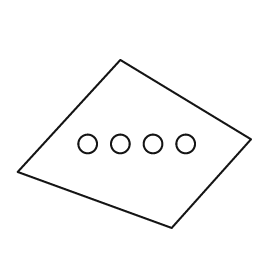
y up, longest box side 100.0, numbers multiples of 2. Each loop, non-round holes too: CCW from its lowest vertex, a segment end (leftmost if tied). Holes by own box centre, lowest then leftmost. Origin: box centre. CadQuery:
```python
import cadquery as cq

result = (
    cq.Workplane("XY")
    .moveTo(16.0, -36.0)
    .lineTo(50.0, 2.0)
    .lineTo(-6.0, 36.0)
    .lineTo(-50.0, -12.0)
    .close()
    .moveTo(-20.0, 0.0)
    .circle(4.0)
    .moveTo(-6.0, 0.0)
    .circle(4.0)
    .moveTo(8.0, 0.0)
    .circle(4.0)
    .moveTo(22.0, 0.0)
    .circle(4.0)
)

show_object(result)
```